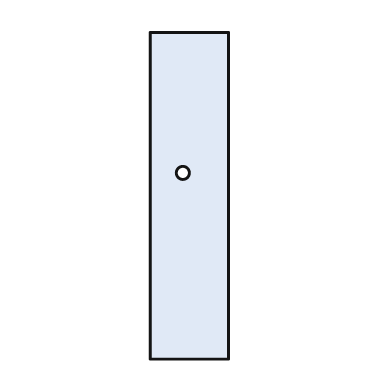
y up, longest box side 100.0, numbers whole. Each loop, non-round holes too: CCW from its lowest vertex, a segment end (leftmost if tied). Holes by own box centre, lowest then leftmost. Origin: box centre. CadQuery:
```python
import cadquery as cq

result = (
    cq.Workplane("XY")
    .moveTo(-12.0, -50.0)
    .lineTo(12.0, -50.0)
    .lineTo(12.0, 50.0)
    .lineTo(-12.0, 50.0)
    .close()
    .moveTo(-2.0, 7.0)
    .circle(2.0)
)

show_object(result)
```